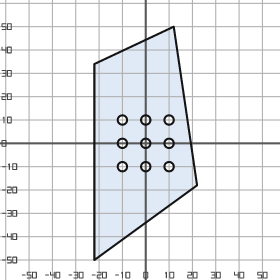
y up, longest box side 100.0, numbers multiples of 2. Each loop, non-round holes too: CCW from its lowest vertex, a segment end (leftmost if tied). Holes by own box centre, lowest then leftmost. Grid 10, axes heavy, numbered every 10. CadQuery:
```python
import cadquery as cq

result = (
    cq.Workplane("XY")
    .moveTo(-22.0, -50.0)
    .lineTo(22.0, -18.0)
    .lineTo(12.0, 50.0)
    .lineTo(-22.0, 34.0)
    .close()
    .moveTo(-10.0, -10.0)
    .circle(2.0)
    .moveTo(0.0, -10.0)
    .circle(2.0)
    .moveTo(10.0, -10.0)
    .circle(2.0)
    .moveTo(-10.0, 0.0)
    .circle(2.0)
    .moveTo(0.0, 0.0)
    .circle(2.0)
    .moveTo(10.0, 0.0)
    .circle(2.0)
    .moveTo(-10.0, 10.0)
    .circle(2.0)
    .moveTo(0.0, 10.0)
    .circle(2.0)
    .moveTo(10.0, 10.0)
    .circle(2.0)
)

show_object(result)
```